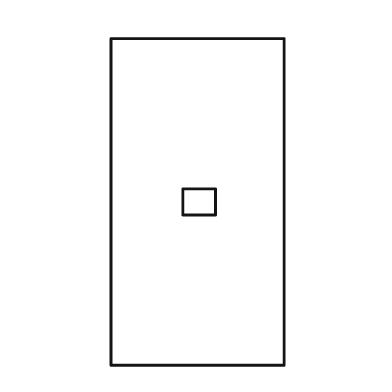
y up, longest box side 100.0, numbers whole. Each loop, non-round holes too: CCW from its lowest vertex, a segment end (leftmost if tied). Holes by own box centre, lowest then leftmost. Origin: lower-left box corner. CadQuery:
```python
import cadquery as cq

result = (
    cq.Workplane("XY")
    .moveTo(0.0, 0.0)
    .lineTo(53.0, 0.0)
    .lineTo(53.0, 100.0)
    .lineTo(0.0, 100.0)
    .close()
    .moveTo(22.0, 46.0)
    .lineTo(32.0, 46.0)
    .lineTo(32.0, 54.0)
    .lineTo(22.0, 54.0)
    .close()
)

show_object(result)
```